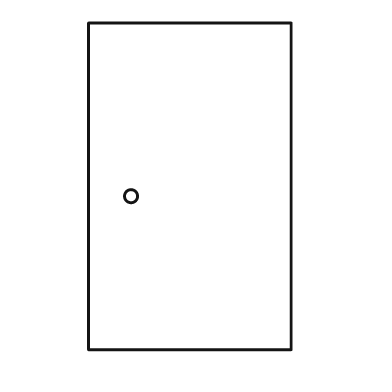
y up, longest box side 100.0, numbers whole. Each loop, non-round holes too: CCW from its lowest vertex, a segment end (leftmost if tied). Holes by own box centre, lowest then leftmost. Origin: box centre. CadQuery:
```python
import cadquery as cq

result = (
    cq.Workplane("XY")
    .moveTo(-31.0, -50.0)
    .lineTo(31.0, -50.0)
    .lineTo(31.0, 50.0)
    .lineTo(-31.0, 50.0)
    .close()
    .moveTo(-18.0, -3.0)
    .circle(2.0)
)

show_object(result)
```